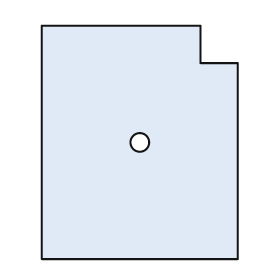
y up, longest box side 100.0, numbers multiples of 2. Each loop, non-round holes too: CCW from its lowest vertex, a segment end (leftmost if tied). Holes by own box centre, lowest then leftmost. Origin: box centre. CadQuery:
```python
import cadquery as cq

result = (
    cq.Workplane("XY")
    .moveTo(-42.0, -50.0)
    .lineTo(42.0, -50.0)
    .lineTo(42.0, 34.0)
    .lineTo(26.0, 34.0)
    .lineTo(26.0, 50.0)
    .lineTo(-42.0, 50.0)
    .close()
    .moveTo(0.0, 0.0)
    .circle(4.0)
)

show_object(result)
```